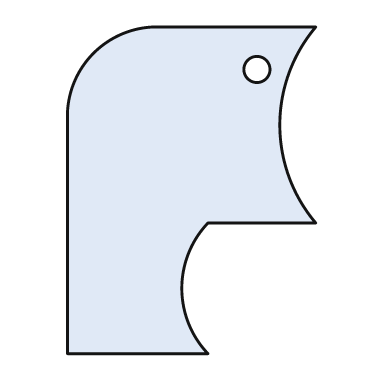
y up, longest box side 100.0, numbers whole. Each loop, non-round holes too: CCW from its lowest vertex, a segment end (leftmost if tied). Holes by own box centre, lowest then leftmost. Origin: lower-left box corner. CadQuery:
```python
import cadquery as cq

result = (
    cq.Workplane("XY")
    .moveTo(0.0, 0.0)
    .lineTo(43.0, 0.0)
    .threePointArc((35.0, 20.0), (43.0, 40.0))
    .lineTo(76.0, 40.0)
    .threePointArc((65.0, 70.0), (76.0, 100.0))
    .lineTo(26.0, 100.0)
    .threePointArc((8.0, 92.0), (0.0, 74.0))
    .close()
    .moveTo(58.0, 87.0)
    .circle(4.0)
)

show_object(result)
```